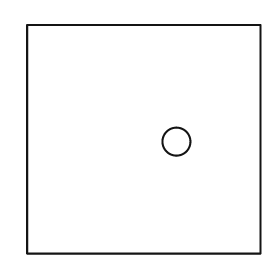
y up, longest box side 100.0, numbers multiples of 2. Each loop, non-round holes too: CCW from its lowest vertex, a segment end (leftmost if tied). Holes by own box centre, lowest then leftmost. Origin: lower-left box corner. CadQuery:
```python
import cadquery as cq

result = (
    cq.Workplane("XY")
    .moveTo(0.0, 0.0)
    .lineTo(100.0, 0.0)
    .lineTo(100.0, 98.0)
    .lineTo(0.0, 98.0)
    .close()
    .moveTo(64.0, 48.0)
    .circle(6.0)
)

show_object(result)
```